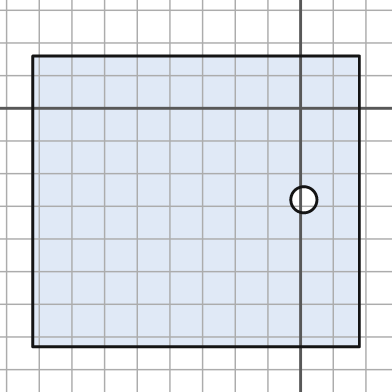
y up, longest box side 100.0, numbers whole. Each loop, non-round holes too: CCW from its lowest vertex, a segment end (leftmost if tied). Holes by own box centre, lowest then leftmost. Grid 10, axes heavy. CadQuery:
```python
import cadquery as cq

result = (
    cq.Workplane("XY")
    .moveTo(-82.0, -73.0)
    .lineTo(18.0, -73.0)
    .lineTo(18.0, 16.0)
    .lineTo(-82.0, 16.0)
    .close()
    .moveTo(1.0, -28.0)
    .circle(4.0)
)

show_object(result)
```